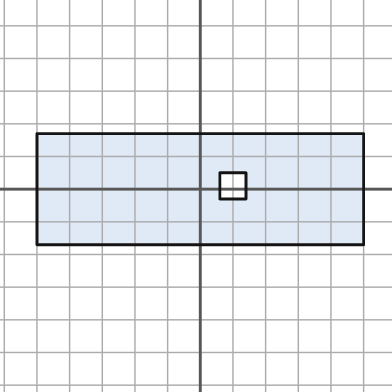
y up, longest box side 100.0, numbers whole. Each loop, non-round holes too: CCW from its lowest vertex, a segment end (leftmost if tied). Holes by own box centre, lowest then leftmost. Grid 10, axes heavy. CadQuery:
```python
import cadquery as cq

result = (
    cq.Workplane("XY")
    .moveTo(-50.0, -17.0)
    .lineTo(50.0, -17.0)
    .lineTo(50.0, 17.0)
    .lineTo(-50.0, 17.0)
    .close()
    .moveTo(6.0, -3.0)
    .lineTo(14.0, -3.0)
    .lineTo(14.0, 5.0)
    .lineTo(6.0, 5.0)
    .close()
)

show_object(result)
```